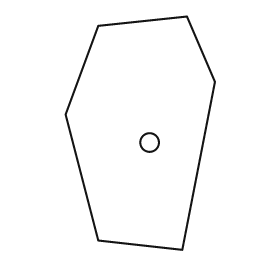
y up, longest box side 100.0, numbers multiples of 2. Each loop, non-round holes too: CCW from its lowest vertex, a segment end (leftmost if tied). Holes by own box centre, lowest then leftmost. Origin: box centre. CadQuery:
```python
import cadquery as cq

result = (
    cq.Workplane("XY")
    .moveTo(18.0, -50.0)
    .lineTo(32.0, 22.0)
    .lineTo(20.0, 50.0)
    .lineTo(-18.0, 46.0)
    .lineTo(-32.0, 8.0)
    .lineTo(-18.0, -46.0)
    .close()
    .moveTo(4.0, -4.0)
    .circle(4.0)
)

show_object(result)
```